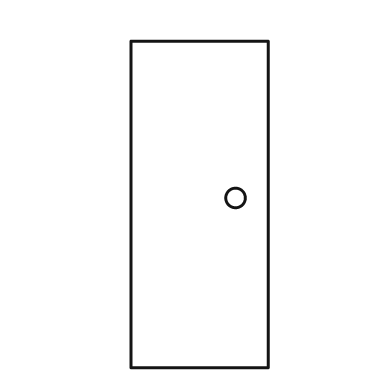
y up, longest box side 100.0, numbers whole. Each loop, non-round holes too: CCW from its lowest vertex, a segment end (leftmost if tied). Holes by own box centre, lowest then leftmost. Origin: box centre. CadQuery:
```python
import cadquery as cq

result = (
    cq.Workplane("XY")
    .moveTo(-21.0, -50.0)
    .lineTo(21.0, -50.0)
    .lineTo(21.0, 50.0)
    .lineTo(-21.0, 50.0)
    .close()
    .moveTo(11.0, 2.0)
    .circle(3.0)
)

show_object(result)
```